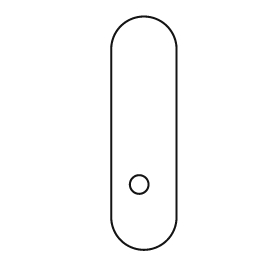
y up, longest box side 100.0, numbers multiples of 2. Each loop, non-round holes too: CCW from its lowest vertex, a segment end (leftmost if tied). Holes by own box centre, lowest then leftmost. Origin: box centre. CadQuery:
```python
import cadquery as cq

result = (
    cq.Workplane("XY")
    .moveTo(-14.0, -36.0)
    .threePointArc((0.0, -50.0), (14.0, -36.0))
    .lineTo(14.0, 36.0)
    .threePointArc((0.0, 50.0), (-14.0, 36.0))
    .close()
    .moveTo(-2.0, -22.0)
    .circle(4.0)
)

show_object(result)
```